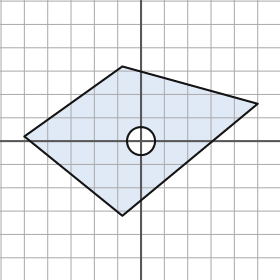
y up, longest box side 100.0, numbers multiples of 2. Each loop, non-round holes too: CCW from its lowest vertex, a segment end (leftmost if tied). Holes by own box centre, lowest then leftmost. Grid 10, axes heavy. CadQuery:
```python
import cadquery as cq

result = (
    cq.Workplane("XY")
    .moveTo(-8.0, -32.0)
    .lineTo(50.0, 16.0)
    .lineTo(-8.0, 32.0)
    .lineTo(-50.0, 2.0)
    .close()
    .moveTo(0.0, 0.0)
    .circle(6.0)
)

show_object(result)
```